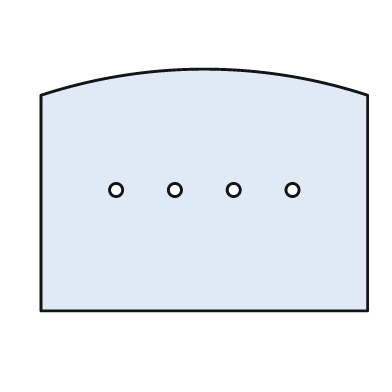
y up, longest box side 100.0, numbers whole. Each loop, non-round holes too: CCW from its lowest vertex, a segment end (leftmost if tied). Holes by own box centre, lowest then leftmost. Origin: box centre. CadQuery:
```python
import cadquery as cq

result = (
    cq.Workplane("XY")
    .moveTo(-50.0, -37.0)
    .lineTo(50.0, -37.0)
    .lineTo(50.0, 29.0)
    .threePointArc((0.0, 37.0), (-50.0, 29.0))
    .close()
    .moveTo(-27.0, 0.0)
    .circle(2.0)
    .moveTo(-9.0, 0.0)
    .circle(2.0)
    .moveTo(9.0, 0.0)
    .circle(2.0)
    .moveTo(27.0, 0.0)
    .circle(2.0)
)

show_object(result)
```